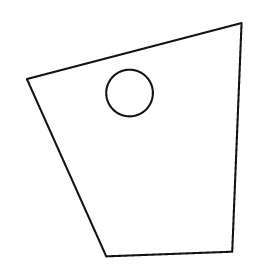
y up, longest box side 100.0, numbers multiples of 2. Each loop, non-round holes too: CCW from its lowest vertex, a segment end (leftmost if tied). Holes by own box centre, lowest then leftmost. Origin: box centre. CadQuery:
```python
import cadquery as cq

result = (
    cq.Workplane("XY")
    .moveTo(-12.0, -50.0)
    .lineTo(42.0, -48.0)
    .lineTo(46.0, 50.0)
    .lineTo(-46.0, 26.0)
    .close()
    .moveTo(-2.0, 20.0)
    .circle(10.0)
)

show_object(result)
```